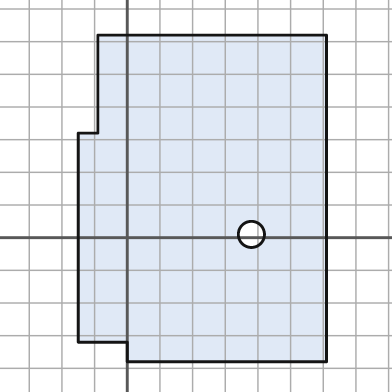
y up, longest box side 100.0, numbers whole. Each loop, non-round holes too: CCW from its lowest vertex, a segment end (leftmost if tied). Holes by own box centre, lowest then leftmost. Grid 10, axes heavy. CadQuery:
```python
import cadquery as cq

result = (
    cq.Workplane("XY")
    .moveTo(0.0, -38.0)
    .lineTo(61.0, -38.0)
    .lineTo(61.0, 62.0)
    .lineTo(-9.0, 62.0)
    .lineTo(-9.0, 32.0)
    .lineTo(-15.0, 32.0)
    .lineTo(-15.0, -32.0)
    .lineTo(0.0, -32.0)
    .close()
    .moveTo(38.0, 1.0)
    .circle(4.0)
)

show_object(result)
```